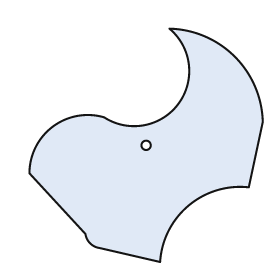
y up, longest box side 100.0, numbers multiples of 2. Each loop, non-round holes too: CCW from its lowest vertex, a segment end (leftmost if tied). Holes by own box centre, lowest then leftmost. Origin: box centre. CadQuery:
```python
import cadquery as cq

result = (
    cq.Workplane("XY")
    .moveTo(6.0, -50.0)
    .threePointArc((18.0, -26.0), (44.0, -18.0))
    .lineTo(50.0, 10.0)
    .threePointArc((38.0, 38.0), (10.0, 50.0))
    .threePointArc((14.0, 18.0), (-18.0, 12.0))
    .threePointArc((-40.0, 8.0), (-50.0, -12.0))
    .lineTo(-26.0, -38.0)
    .threePointArc((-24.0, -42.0), (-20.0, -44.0))
    .close()
    .moveTo(0.0, 0.0)
    .circle(2.0)
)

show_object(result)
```